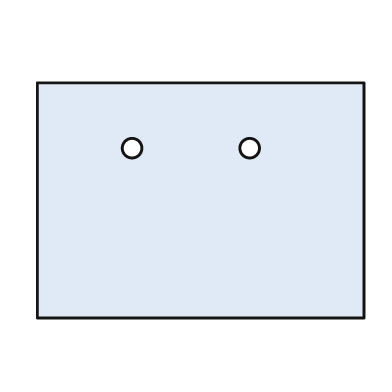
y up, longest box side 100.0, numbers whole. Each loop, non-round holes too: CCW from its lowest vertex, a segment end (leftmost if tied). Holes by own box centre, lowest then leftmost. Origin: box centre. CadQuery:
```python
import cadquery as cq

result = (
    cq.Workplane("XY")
    .moveTo(-50.0, -36.0)
    .lineTo(50.0, -36.0)
    .lineTo(50.0, 36.0)
    .lineTo(-50.0, 36.0)
    .close()
    .moveTo(-21.0, 16.0)
    .circle(3.0)
    .moveTo(15.0, 16.0)
    .circle(3.0)
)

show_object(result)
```